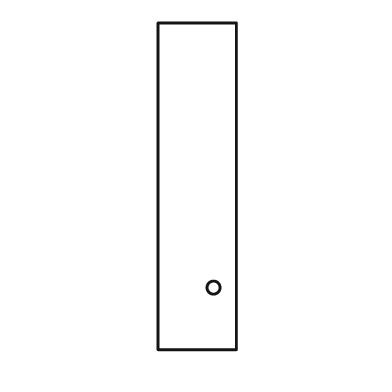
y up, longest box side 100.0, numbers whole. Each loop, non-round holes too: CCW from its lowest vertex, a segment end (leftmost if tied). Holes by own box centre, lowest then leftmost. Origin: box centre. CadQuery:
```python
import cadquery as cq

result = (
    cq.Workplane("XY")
    .moveTo(-12.0, -50.0)
    .lineTo(12.0, -50.0)
    .lineTo(12.0, 50.0)
    .lineTo(-12.0, 50.0)
    .close()
    .moveTo(5.0, -31.0)
    .circle(2.0)
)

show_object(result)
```